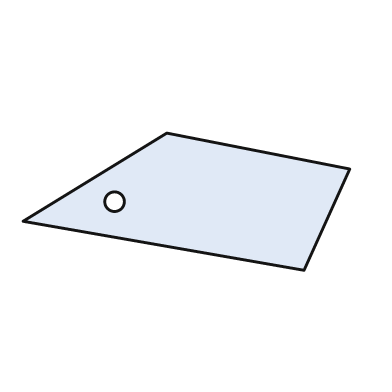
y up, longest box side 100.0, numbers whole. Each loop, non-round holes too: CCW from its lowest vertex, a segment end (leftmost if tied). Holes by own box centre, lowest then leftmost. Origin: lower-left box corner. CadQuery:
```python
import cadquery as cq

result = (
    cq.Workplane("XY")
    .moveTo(86.0, 0.0)
    .lineTo(100.0, 31.0)
    .lineTo(44.0, 42.0)
    .lineTo(0.0, 15.0)
    .close()
    .moveTo(28.0, 21.0)
    .circle(3.0)
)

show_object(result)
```